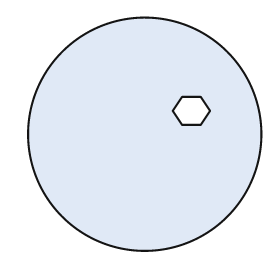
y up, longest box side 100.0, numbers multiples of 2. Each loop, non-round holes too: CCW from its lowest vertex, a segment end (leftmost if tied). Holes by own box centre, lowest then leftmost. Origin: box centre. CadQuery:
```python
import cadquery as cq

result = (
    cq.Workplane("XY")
    .moveTo(0.0, 0.0)
    .circle(50.0)
    .moveTo(16.0, 4.0)
    .lineTo(24.0, 4.0)
    .lineTo(28.0, 10.0)
    .lineTo(24.0, 16.0)
    .lineTo(16.0, 16.0)
    .lineTo(12.0, 10.0)
    .close()
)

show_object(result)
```